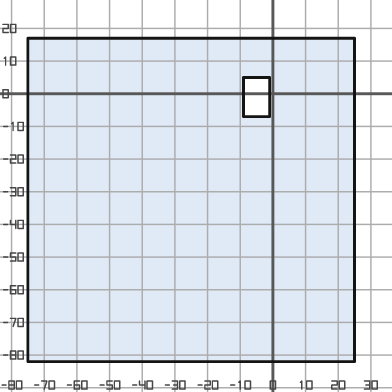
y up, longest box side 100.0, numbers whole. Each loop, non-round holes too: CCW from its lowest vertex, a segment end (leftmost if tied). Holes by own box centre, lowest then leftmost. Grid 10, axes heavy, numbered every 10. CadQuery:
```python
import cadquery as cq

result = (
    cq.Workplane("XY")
    .moveTo(-75.0, -82.0)
    .lineTo(25.0, -82.0)
    .lineTo(25.0, 17.0)
    .lineTo(-75.0, 17.0)
    .close()
    .moveTo(-9.0, -7.0)
    .lineTo(-1.0, -7.0)
    .lineTo(-1.0, 5.0)
    .lineTo(-9.0, 5.0)
    .close()
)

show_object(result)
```